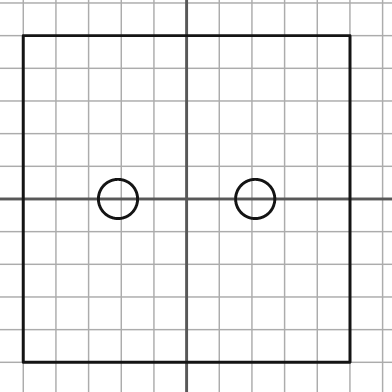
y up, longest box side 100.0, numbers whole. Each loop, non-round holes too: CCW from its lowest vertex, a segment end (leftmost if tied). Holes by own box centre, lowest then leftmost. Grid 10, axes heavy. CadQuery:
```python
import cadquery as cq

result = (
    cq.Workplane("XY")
    .moveTo(-50.0, -50.0)
    .lineTo(50.0, -50.0)
    .lineTo(50.0, 50.0)
    .lineTo(-50.0, 50.0)
    .close()
    .moveTo(-21.0, 0.0)
    .circle(6.0)
    .moveTo(21.0, 0.0)
    .circle(6.0)
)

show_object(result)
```